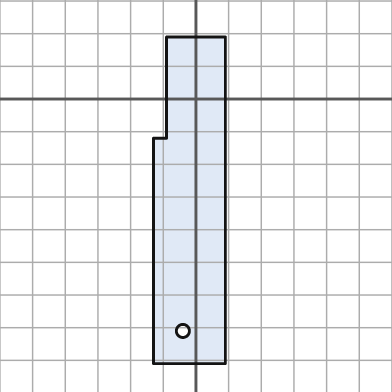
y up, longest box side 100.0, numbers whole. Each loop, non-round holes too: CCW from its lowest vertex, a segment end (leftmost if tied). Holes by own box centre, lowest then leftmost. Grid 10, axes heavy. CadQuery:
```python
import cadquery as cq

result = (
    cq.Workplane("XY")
    .moveTo(-13.0, -81.0)
    .lineTo(9.0, -81.0)
    .lineTo(9.0, 19.0)
    .lineTo(-9.0, 19.0)
    .lineTo(-9.0, -12.0)
    .lineTo(-13.0, -12.0)
    .close()
    .moveTo(-4.0, -71.0)
    .circle(2.0)
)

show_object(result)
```